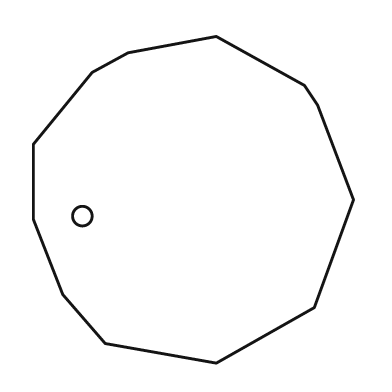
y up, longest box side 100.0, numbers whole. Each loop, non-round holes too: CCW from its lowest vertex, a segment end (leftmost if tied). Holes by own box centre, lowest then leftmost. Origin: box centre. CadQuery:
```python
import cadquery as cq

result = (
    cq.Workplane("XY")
    .moveTo(7.0, -50.0)
    .lineTo(37.0, -33.0)
    .lineTo(49.0, 0.0)
    .lineTo(38.0, 29.0)
    .lineTo(34.0, 35.0)
    .lineTo(7.0, 50.0)
    .lineTo(-20.0, 45.0)
    .lineTo(-31.0, 39.0)
    .lineTo(-49.0, 17.0)
    .lineTo(-49.0, -6.0)
    .lineTo(-40.0, -29.0)
    .lineTo(-27.0, -44.0)
    .close()
    .moveTo(-34.0, -5.0)
    .circle(3.0)
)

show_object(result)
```